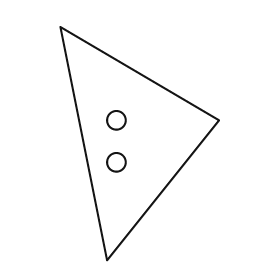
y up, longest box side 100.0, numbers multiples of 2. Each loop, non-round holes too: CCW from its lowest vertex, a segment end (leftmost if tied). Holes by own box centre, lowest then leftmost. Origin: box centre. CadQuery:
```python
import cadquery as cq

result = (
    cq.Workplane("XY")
    .moveTo(-14.0, -50.0)
    .lineTo(34.0, 10.0)
    .lineTo(-34.0, 50.0)
    .close()
    .moveTo(-10.0, -8.0)
    .circle(4.0)
    .moveTo(-10.0, 10.0)
    .circle(4.0)
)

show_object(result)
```